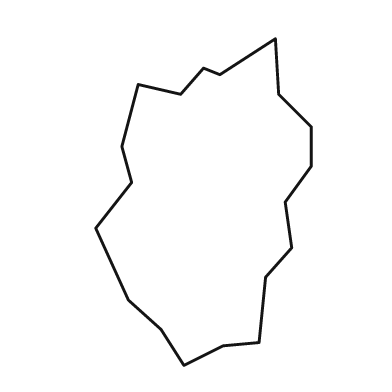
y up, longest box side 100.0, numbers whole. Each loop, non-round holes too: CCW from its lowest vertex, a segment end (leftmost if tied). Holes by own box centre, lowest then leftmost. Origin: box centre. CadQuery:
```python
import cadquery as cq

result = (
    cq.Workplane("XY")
    .moveTo(-6.0, -50.0)
    .lineTo(6.0, -44.0)
    .lineTo(17.0, -43.0)
    .lineTo(19.0, -23.0)
    .lineTo(27.0, -14.0)
    .lineTo(25.0, 0.0)
    .lineTo(33.0, 11.0)
    .lineTo(33.0, 23.0)
    .lineTo(23.0, 33.0)
    .lineTo(22.0, 50.0)
    .lineTo(5.0, 39.0)
    .lineTo(0.0, 41.0)
    .lineTo(-7.0, 33.0)
    .lineTo(-20.0, 36.0)
    .lineTo(-25.0, 17.0)
    .lineTo(-22.0, 6.0)
    .lineTo(-33.0, -8.0)
    .lineTo(-23.0, -30.0)
    .lineTo(-13.0, -39.0)
    .close()
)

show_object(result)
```